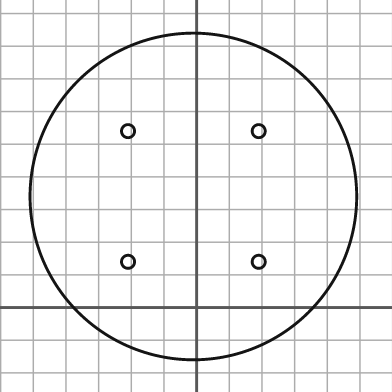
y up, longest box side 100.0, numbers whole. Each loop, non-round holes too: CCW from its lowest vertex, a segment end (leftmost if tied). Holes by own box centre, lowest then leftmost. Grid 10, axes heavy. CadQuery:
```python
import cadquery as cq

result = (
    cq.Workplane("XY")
    .moveTo(-1.0, 34.0)
    .circle(50.0)
    .moveTo(-21.0, 14.0)
    .circle(2.0)
    .moveTo(19.0, 14.0)
    .circle(2.0)
    .moveTo(-21.0, 54.0)
    .circle(2.0)
    .moveTo(19.0, 54.0)
    .circle(2.0)
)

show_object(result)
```